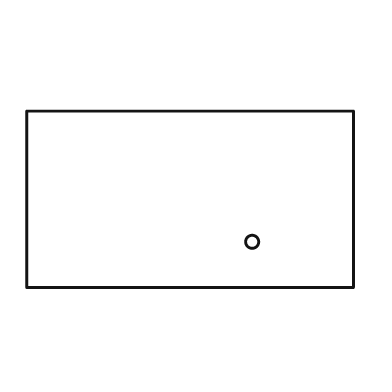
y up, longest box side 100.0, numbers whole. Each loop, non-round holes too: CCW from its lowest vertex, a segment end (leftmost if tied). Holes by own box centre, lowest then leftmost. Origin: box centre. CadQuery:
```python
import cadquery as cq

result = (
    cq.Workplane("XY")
    .moveTo(-50.0, -27.0)
    .lineTo(50.0, -27.0)
    .lineTo(50.0, 27.0)
    .lineTo(-50.0, 27.0)
    .close()
    .moveTo(19.0, -13.0)
    .circle(2.0)
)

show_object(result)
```